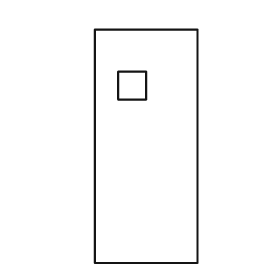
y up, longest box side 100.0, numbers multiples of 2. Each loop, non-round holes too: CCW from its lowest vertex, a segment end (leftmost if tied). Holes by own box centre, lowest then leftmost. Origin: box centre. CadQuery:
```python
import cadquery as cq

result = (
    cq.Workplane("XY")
    .moveTo(-22.0, -50.0)
    .lineTo(22.0, -50.0)
    .lineTo(22.0, 50.0)
    .lineTo(-22.0, 50.0)
    .close()
    .moveTo(-12.0, 20.0)
    .lineTo(0.0, 20.0)
    .lineTo(0.0, 32.0)
    .lineTo(-12.0, 32.0)
    .close()
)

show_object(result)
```